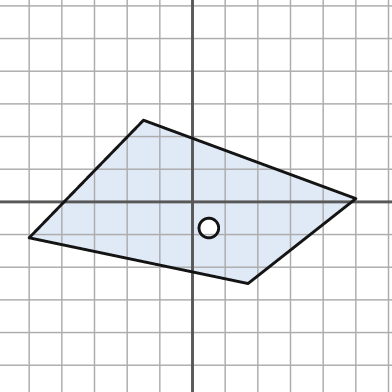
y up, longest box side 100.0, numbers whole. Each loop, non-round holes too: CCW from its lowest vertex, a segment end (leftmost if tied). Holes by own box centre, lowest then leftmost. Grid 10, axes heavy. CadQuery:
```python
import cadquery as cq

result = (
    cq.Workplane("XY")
    .moveTo(17.0, -25.0)
    .lineTo(50.0, 1.0)
    .lineTo(-15.0, 25.0)
    .lineTo(-50.0, -11.0)
    .close()
    .moveTo(5.0, -8.0)
    .circle(3.0)
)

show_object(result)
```